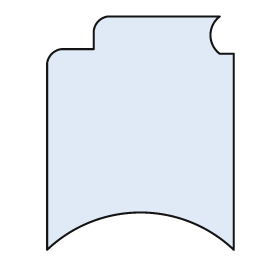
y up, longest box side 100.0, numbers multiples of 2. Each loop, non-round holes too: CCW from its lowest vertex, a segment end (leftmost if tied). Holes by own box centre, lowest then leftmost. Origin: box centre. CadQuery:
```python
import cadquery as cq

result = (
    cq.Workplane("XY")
    .moveTo(-40.0, -50.0)
    .threePointArc((0.0, -34.0), (40.0, -50.0))
    .lineTo(40.0, 34.0)
    .lineTo(34.0, 34.0)
    .threePointArc((30.0, 42.0), (34.0, 50.0))
    .lineTo(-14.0, 50.0)
    .threePointArc((-18.0, 48.0), (-20.0, 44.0))
    .lineTo(-20.0, 36.0)
    .lineTo(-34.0, 36.0)
    .threePointArc((-38.0, 34.0), (-40.0, 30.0))
    .close()
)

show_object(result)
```